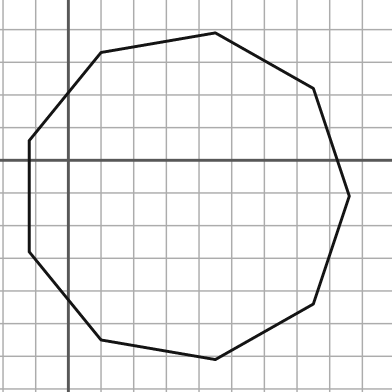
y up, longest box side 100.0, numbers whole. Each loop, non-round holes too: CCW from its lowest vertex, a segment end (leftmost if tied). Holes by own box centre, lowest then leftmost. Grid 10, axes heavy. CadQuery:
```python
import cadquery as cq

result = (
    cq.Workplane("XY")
    .moveTo(45.0, -61.0)
    .lineTo(75.0, -44.0)
    .lineTo(86.0, -11.0)
    .lineTo(75.0, 22.0)
    .lineTo(45.0, 39.0)
    .lineTo(10.0, 33.0)
    .lineTo(-12.0, 6.0)
    .lineTo(-12.0, -28.0)
    .lineTo(10.0, -55.0)
    .close()
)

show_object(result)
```